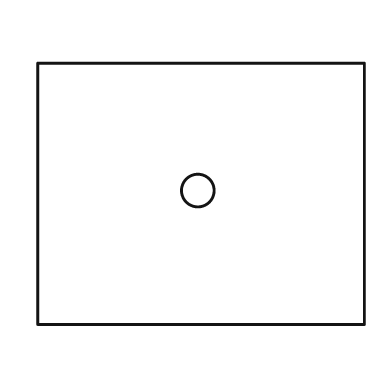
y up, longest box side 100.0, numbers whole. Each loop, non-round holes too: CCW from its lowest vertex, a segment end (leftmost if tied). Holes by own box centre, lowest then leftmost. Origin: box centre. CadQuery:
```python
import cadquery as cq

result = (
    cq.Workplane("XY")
    .moveTo(-50.0, -40.0)
    .lineTo(50.0, -40.0)
    .lineTo(50.0, 40.0)
    .lineTo(-50.0, 40.0)
    .close()
    .moveTo(-1.0, 1.0)
    .circle(5.0)
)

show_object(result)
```